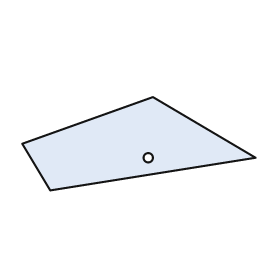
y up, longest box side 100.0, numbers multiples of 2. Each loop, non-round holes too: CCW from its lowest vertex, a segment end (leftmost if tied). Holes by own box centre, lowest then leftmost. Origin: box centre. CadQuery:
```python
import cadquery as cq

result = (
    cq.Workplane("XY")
    .moveTo(-38.0, -20.0)
    .lineTo(50.0, -6.0)
    .lineTo(6.0, 20.0)
    .lineTo(-50.0, 0.0)
    .close()
    .moveTo(4.0, -6.0)
    .circle(2.0)
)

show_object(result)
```